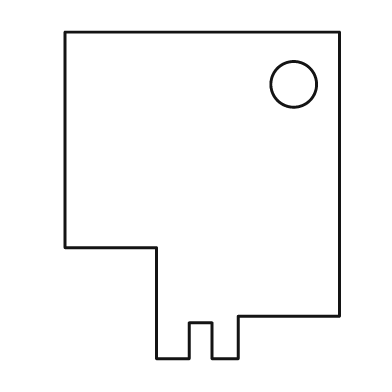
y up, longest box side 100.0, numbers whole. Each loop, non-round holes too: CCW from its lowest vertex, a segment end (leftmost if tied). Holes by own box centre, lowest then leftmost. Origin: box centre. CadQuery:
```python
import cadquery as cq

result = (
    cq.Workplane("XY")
    .moveTo(-14.0, -50.0)
    .lineTo(-4.0, -50.0)
    .lineTo(-4.0, -39.0)
    .lineTo(3.0, -39.0)
    .lineTo(3.0, -50.0)
    .lineTo(11.0, -50.0)
    .lineTo(11.0, -37.0)
    .lineTo(42.0, -37.0)
    .lineTo(42.0, 50.0)
    .lineTo(-42.0, 50.0)
    .lineTo(-42.0, -16.0)
    .lineTo(-14.0, -16.0)
    .close()
    .moveTo(28.0, 34.0)
    .circle(7.0)
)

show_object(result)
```